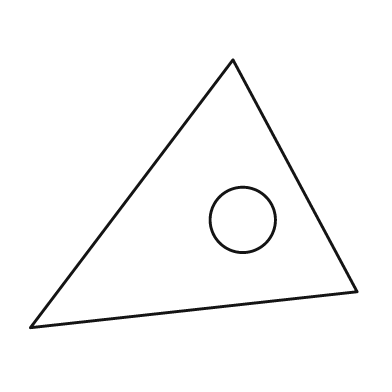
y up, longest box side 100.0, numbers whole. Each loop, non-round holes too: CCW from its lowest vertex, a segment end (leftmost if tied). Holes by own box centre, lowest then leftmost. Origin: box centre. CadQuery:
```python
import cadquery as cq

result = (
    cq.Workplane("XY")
    .moveTo(-50.0, -41.0)
    .lineTo(50.0, -30.0)
    .lineTo(12.0, 41.0)
    .close()
    .moveTo(15.0, -8.0)
    .circle(10.0)
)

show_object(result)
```